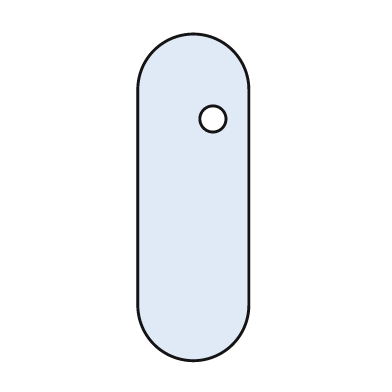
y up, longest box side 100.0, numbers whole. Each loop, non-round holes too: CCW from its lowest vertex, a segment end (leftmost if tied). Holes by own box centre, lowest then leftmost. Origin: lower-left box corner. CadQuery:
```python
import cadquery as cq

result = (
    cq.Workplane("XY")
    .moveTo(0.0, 17.0)
    .threePointArc((17.0, 0.0), (34.0, 17.0))
    .lineTo(34.0, 83.0)
    .threePointArc((17.0, 100.0), (0.0, 83.0))
    .close()
    .moveTo(23.0, 74.0)
    .circle(4.0)
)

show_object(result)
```